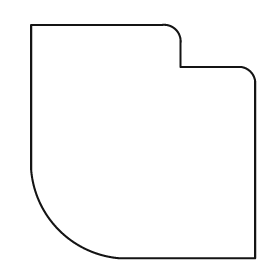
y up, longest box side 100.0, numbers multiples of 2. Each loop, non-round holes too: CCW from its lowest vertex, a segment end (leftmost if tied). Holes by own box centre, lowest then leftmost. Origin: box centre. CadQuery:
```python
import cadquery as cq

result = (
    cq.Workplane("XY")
    .moveTo(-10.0, -50.0)
    .lineTo(48.0, -50.0)
    .lineTo(48.0, 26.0)
    .threePointArc((46.0, 30.0), (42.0, 32.0))
    .lineTo(16.0, 32.0)
    .lineTo(16.0, 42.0)
    .threePointArc((14.0, 48.0), (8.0, 50.0))
    .lineTo(-48.0, 50.0)
    .lineTo(-48.0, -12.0)
    .threePointArc((-36.0, -38.0), (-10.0, -50.0))
    .close()
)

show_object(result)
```